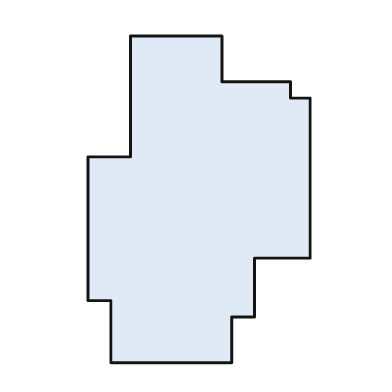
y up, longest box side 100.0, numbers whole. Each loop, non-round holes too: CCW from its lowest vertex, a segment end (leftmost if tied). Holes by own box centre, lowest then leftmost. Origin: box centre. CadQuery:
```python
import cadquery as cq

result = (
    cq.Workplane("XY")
    .moveTo(-27.0, -50.0)
    .lineTo(10.0, -50.0)
    .lineTo(10.0, -36.0)
    .lineTo(17.0, -36.0)
    .lineTo(17.0, -18.0)
    .lineTo(34.0, -18.0)
    .lineTo(34.0, 31.0)
    .lineTo(28.0, 31.0)
    .lineTo(28.0, 36.0)
    .lineTo(7.0, 36.0)
    .lineTo(7.0, 50.0)
    .lineTo(-21.0, 50.0)
    .lineTo(-21.0, 13.0)
    .lineTo(-34.0, 13.0)
    .lineTo(-34.0, -31.0)
    .lineTo(-27.0, -31.0)
    .close()
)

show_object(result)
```